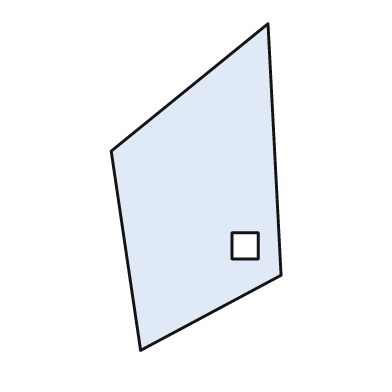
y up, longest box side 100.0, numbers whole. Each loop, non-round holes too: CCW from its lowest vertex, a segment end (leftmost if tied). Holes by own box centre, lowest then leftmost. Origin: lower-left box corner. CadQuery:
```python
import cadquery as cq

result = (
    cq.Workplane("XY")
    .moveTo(9.0, 0.0)
    .lineTo(52.0, 23.0)
    .lineTo(48.0, 100.0)
    .lineTo(0.0, 61.0)
    .close()
    .moveTo(37.0, 28.0)
    .lineTo(45.0, 28.0)
    .lineTo(45.0, 36.0)
    .lineTo(37.0, 36.0)
    .close()
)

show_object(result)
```